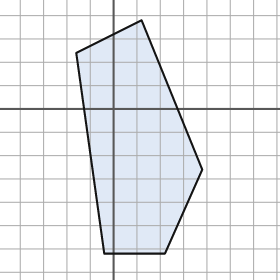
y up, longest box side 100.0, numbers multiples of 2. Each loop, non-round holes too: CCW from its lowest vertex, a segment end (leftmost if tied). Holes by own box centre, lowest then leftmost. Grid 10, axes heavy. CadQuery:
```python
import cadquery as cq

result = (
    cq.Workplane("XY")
    .moveTo(-4.0, -62.0)
    .lineTo(22.0, -62.0)
    .lineTo(38.0, -26.0)
    .lineTo(12.0, 38.0)
    .lineTo(-16.0, 24.0)
    .close()
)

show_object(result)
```